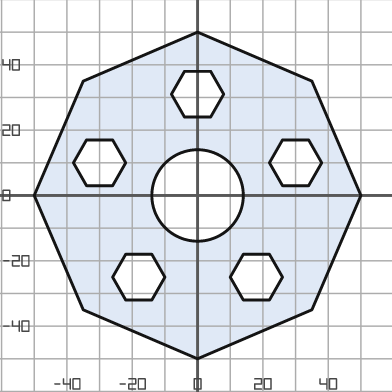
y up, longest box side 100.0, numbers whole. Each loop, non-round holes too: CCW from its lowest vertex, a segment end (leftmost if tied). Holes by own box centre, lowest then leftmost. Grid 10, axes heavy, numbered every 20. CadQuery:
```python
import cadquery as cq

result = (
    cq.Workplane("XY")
    .moveTo(0.0, -50.0)
    .lineTo(35.0, -35.0)
    .lineTo(50.0, 0.0)
    .lineTo(35.0, 35.0)
    .lineTo(0.0, 50.0)
    .lineTo(-35.0, 35.0)
    .lineTo(-50.0, 0.0)
    .lineTo(-35.0, -35.0)
    .close()
    .moveTo(-22.0, -32.0)
    .lineTo(-14.0, -32.0)
    .lineTo(-10.0, -25.0)
    .lineTo(-14.0, -18.0)
    .lineTo(-22.0, -18.0)
    .lineTo(-26.0, -25.0)
    .close()
    .moveTo(14.0, -32.0)
    .lineTo(22.0, -32.0)
    .lineTo(26.0, -25.0)
    .lineTo(22.0, -18.0)
    .lineTo(14.0, -18.0)
    .lineTo(10.0, -25.0)
    .close()
    .moveTo(0.0, 0.0)
    .circle(14.0)
    .moveTo(-34.0, 3.0)
    .lineTo(-26.0, 3.0)
    .lineTo(-22.0, 10.0)
    .lineTo(-26.0, 17.0)
    .lineTo(-34.0, 17.0)
    .lineTo(-38.0, 10.0)
    .close()
    .moveTo(26.0, 3.0)
    .lineTo(34.0, 3.0)
    .lineTo(38.0, 10.0)
    .lineTo(34.0, 17.0)
    .lineTo(26.0, 17.0)
    .lineTo(22.0, 10.0)
    .close()
    .moveTo(-4.0, 24.0)
    .lineTo(4.0, 24.0)
    .lineTo(8.0, 31.0)
    .lineTo(4.0, 38.0)
    .lineTo(-4.0, 38.0)
    .lineTo(-8.0, 31.0)
    .close()
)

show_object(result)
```